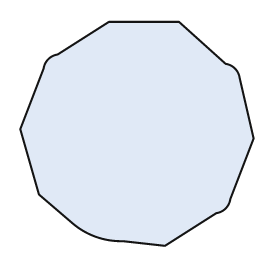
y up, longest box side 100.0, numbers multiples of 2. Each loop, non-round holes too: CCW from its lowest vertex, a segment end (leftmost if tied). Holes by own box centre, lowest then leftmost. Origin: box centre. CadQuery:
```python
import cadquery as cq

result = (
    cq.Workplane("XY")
    .moveTo(12.0, -48.0)
    .lineTo(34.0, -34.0)
    .threePointArc((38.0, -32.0), (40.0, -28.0))
    .lineTo(50.0, -2.0)
    .lineTo(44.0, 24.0)
    .threePointArc((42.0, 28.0), (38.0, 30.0))
    .lineTo(18.0, 48.0)
    .lineTo(-12.0, 48.0)
    .lineTo(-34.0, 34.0)
    .threePointArc((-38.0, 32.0), (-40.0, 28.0))
    .lineTo(-50.0, 2.0)
    .lineTo(-42.0, -26.0)
    .lineTo(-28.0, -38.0)
    .threePointArc((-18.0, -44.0), (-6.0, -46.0))
    .close()
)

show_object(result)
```